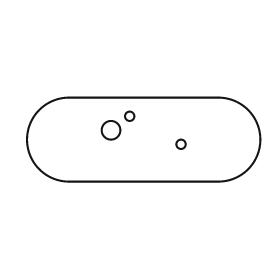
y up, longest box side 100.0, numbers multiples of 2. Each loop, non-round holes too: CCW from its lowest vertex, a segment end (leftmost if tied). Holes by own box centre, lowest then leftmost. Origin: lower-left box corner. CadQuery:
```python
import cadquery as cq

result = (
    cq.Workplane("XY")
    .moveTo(18.0, 0.0)
    .lineTo(82.0, 0.0)
    .threePointArc((100.0, 18.0), (82.0, 36.0))
    .lineTo(18.0, 36.0)
    .threePointArc((0.0, 18.0), (18.0, 0.0))
    .close()
    .moveTo(66.0, 16.0)
    .circle(2.0)
    .moveTo(36.0, 22.0)
    .circle(4.0)
    .moveTo(44.0, 28.0)
    .circle(2.0)
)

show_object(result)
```